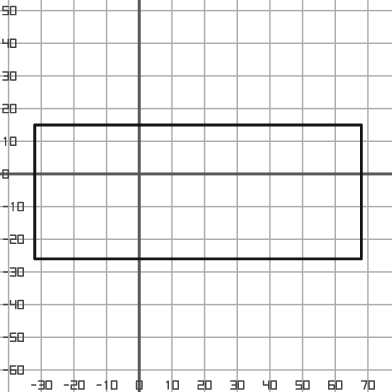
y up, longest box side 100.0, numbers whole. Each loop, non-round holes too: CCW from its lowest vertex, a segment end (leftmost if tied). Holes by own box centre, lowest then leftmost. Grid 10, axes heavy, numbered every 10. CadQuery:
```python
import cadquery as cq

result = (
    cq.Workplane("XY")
    .moveTo(-32.0, -26.0)
    .lineTo(68.0, -26.0)
    .lineTo(68.0, 15.0)
    .lineTo(-32.0, 15.0)
    .close()
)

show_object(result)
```